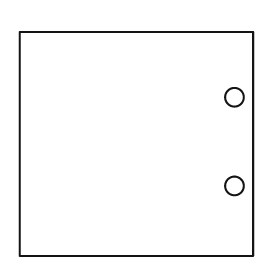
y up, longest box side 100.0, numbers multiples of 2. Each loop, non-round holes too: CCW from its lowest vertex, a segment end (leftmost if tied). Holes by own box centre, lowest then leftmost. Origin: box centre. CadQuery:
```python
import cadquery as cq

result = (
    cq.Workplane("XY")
    .moveTo(-50.0, -48.0)
    .lineTo(50.0, -48.0)
    .lineTo(50.0, 48.0)
    .lineTo(-50.0, 48.0)
    .close()
    .moveTo(42.0, -18.0)
    .circle(4.0)
    .moveTo(42.0, 20.0)
    .circle(4.0)
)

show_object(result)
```